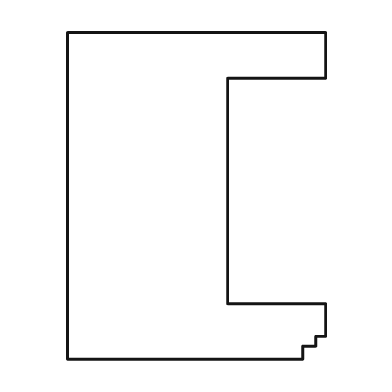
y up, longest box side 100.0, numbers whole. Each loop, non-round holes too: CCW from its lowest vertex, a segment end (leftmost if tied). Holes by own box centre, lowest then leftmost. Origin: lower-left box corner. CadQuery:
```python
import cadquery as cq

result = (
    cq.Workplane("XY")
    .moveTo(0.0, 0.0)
    .lineTo(72.0, 0.0)
    .lineTo(72.0, 4.0)
    .lineTo(76.0, 4.0)
    .lineTo(76.0, 7.0)
    .lineTo(79.0, 7.0)
    .lineTo(79.0, 17.0)
    .lineTo(49.0, 17.0)
    .lineTo(49.0, 86.0)
    .lineTo(79.0, 86.0)
    .lineTo(79.0, 100.0)
    .lineTo(0.0, 100.0)
    .close()
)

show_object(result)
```